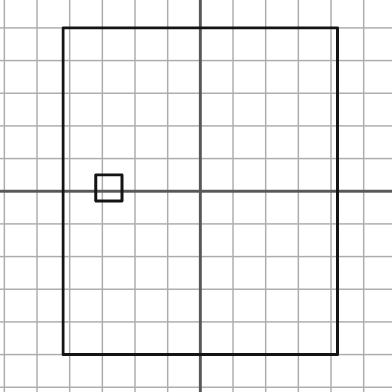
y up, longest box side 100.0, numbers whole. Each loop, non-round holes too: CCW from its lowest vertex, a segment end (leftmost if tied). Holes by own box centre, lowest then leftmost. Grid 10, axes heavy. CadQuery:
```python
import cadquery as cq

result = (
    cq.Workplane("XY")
    .moveTo(-42.0, -50.0)
    .lineTo(42.0, -50.0)
    .lineTo(42.0, 50.0)
    .lineTo(-42.0, 50.0)
    .close()
    .moveTo(-32.0, -3.0)
    .lineTo(-24.0, -3.0)
    .lineTo(-24.0, 5.0)
    .lineTo(-32.0, 5.0)
    .close()
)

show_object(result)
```